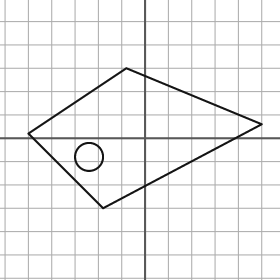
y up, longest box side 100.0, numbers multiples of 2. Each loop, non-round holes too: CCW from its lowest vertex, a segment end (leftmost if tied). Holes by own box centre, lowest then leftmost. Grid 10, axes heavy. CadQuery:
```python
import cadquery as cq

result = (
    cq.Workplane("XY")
    .moveTo(-18.0, -30.0)
    .lineTo(50.0, 6.0)
    .lineTo(-8.0, 30.0)
    .lineTo(-50.0, 2.0)
    .close()
    .moveTo(-24.0, -8.0)
    .circle(6.0)
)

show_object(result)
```